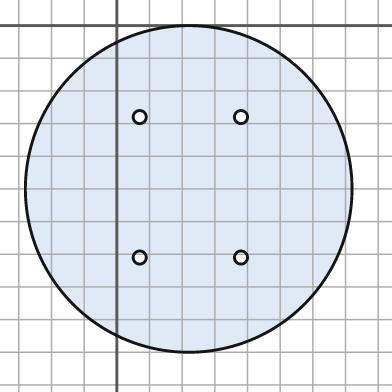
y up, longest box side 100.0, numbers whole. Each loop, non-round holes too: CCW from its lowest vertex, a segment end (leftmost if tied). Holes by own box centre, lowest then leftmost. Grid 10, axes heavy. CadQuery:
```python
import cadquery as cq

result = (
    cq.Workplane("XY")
    .moveTo(22.0, -50.0)
    .circle(50.0)
    .moveTo(7.0, -71.0)
    .circle(2.0)
    .moveTo(38.0, -71.0)
    .circle(2.0)
    .moveTo(7.0, -28.0)
    .circle(2.0)
    .moveTo(38.0, -28.0)
    .circle(2.0)
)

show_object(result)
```